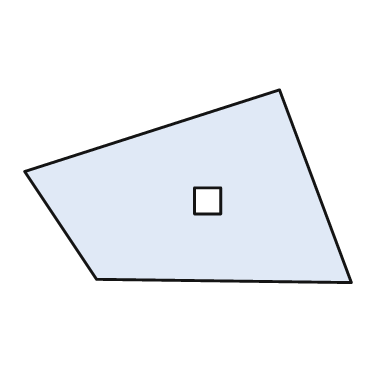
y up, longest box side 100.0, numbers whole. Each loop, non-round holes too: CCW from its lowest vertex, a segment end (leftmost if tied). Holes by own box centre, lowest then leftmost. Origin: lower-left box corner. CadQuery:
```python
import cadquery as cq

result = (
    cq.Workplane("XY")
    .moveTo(100.0, 0.0)
    .lineTo(78.0, 59.0)
    .lineTo(0.0, 34.0)
    .lineTo(22.0, 1.0)
    .close()
    .moveTo(52.0, 21.0)
    .lineTo(60.0, 21.0)
    .lineTo(60.0, 29.0)
    .lineTo(52.0, 29.0)
    .close()
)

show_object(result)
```